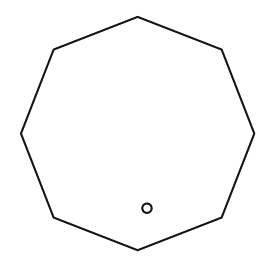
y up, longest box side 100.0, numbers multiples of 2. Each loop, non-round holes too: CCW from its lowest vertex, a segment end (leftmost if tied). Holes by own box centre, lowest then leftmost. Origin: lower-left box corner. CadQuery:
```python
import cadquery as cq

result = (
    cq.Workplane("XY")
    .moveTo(50.0, 0.0)
    .lineTo(86.0, 14.0)
    .lineTo(100.0, 50.0)
    .lineTo(86.0, 86.0)
    .lineTo(50.0, 100.0)
    .lineTo(14.0, 86.0)
    .lineTo(0.0, 50.0)
    .lineTo(14.0, 14.0)
    .close()
    .moveTo(54.0, 18.0)
    .circle(2.0)
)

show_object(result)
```